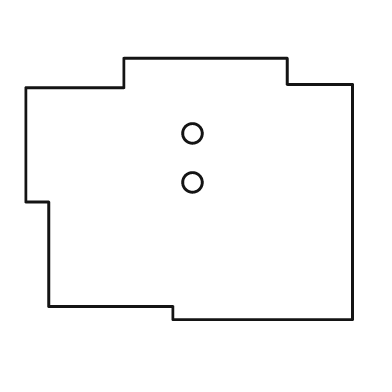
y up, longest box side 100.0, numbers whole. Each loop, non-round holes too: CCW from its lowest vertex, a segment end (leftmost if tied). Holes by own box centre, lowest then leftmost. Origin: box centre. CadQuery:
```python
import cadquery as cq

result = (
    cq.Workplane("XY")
    .moveTo(-5.0, -40.0)
    .lineTo(50.0, -40.0)
    .lineTo(50.0, 32.0)
    .lineTo(30.0, 32.0)
    .lineTo(30.0, 40.0)
    .lineTo(-20.0, 40.0)
    .lineTo(-20.0, 31.0)
    .lineTo(-50.0, 31.0)
    .lineTo(-50.0, -4.0)
    .lineTo(-43.0, -4.0)
    .lineTo(-43.0, -36.0)
    .lineTo(-5.0, -36.0)
    .close()
    .moveTo(1.0, 2.0)
    .circle(3.0)
    .moveTo(1.0, 17.0)
    .circle(3.0)
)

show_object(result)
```